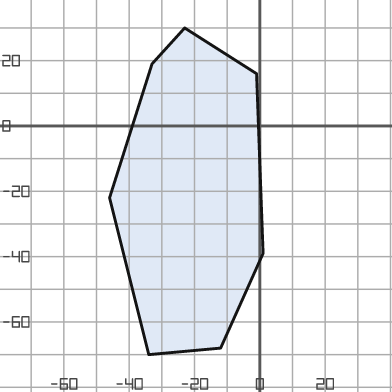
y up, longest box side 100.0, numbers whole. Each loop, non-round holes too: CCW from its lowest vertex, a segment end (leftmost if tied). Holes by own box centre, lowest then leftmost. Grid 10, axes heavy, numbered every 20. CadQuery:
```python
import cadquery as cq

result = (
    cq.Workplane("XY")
    .moveTo(-34.0, -70.0)
    .lineTo(-12.0, -68.0)
    .lineTo(1.0, -39.0)
    .lineTo(-1.0, 16.0)
    .lineTo(-23.0, 30.0)
    .lineTo(-33.0, 19.0)
    .lineTo(-46.0, -22.0)
    .close()
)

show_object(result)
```